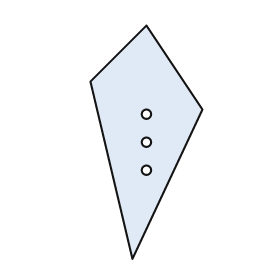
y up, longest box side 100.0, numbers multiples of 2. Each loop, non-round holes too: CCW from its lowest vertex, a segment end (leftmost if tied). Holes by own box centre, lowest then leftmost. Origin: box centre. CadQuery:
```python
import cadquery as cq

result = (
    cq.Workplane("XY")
    .moveTo(-6.0, -50.0)
    .lineTo(24.0, 14.0)
    .lineTo(0.0, 50.0)
    .lineTo(-24.0, 26.0)
    .close()
    .moveTo(0.0, -12.0)
    .circle(2.0)
    .moveTo(0.0, 0.0)
    .circle(2.0)
    .moveTo(0.0, 12.0)
    .circle(2.0)
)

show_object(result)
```